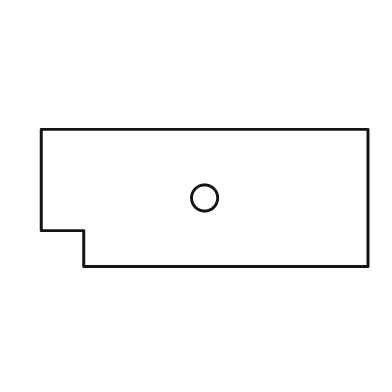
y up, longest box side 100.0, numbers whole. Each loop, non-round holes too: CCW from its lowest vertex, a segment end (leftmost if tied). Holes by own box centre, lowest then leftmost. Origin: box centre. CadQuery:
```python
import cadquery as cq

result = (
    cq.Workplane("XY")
    .moveTo(-37.0, -21.0)
    .lineTo(50.0, -21.0)
    .lineTo(50.0, 21.0)
    .lineTo(-50.0, 21.0)
    .lineTo(-50.0, -10.0)
    .lineTo(-37.0, -10.0)
    .close()
    .moveTo(0.0, 0.0)
    .circle(4.0)
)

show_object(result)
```